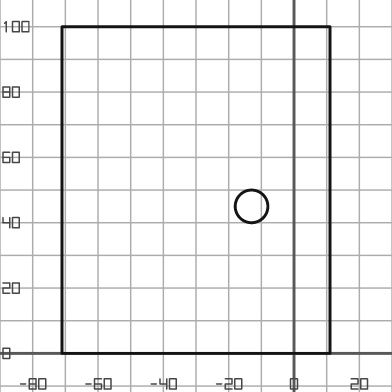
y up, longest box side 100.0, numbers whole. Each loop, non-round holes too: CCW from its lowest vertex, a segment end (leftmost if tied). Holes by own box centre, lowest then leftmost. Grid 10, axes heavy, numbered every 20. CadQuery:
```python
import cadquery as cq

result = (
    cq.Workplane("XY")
    .moveTo(-71.0, 0.0)
    .lineTo(11.0, 0.0)
    .lineTo(11.0, 100.0)
    .lineTo(-71.0, 100.0)
    .close()
    .moveTo(-13.0, 45.0)
    .circle(5.0)
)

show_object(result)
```